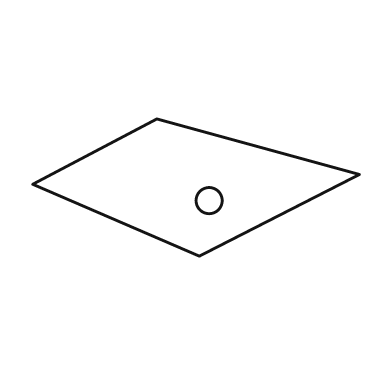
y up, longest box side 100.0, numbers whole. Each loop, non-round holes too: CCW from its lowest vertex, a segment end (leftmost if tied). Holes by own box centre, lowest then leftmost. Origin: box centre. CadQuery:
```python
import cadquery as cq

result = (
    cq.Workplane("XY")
    .moveTo(1.0, -21.0)
    .lineTo(50.0, 4.0)
    .lineTo(-12.0, 21.0)
    .lineTo(-50.0, 1.0)
    .close()
    .moveTo(4.0, -4.0)
    .circle(4.0)
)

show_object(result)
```